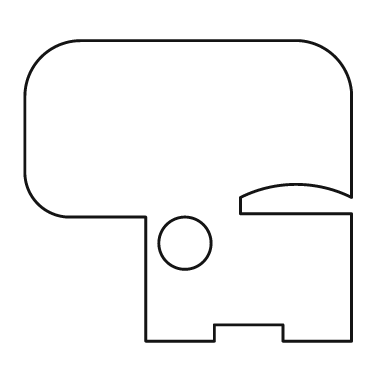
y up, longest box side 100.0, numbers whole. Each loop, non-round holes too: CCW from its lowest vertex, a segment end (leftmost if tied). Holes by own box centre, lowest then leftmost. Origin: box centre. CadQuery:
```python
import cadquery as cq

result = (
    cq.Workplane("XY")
    .moveTo(-13.0, -46.0)
    .lineTo(8.0, -46.0)
    .lineTo(8.0, -41.0)
    .lineTo(29.0, -41.0)
    .lineTo(29.0, -46.0)
    .lineTo(50.0, -46.0)
    .lineTo(50.0, -7.0)
    .lineTo(16.0, -7.0)
    .lineTo(16.0, -2.0)
    .threePointArc((33.0, 2.0), (50.0, -2.0))
    .lineTo(50.0, 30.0)
    .threePointArc((45.0, 41.0), (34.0, 46.0))
    .lineTo(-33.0, 46.0)
    .threePointArc((-45.0, 41.0), (-50.0, 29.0))
    .lineTo(-50.0, 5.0)
    .threePointArc((-46.0, -4.0), (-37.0, -8.0))
    .lineTo(-13.0, -8.0)
    .close()
    .moveTo(-1.0, -16.0)
    .circle(8.0)
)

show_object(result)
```